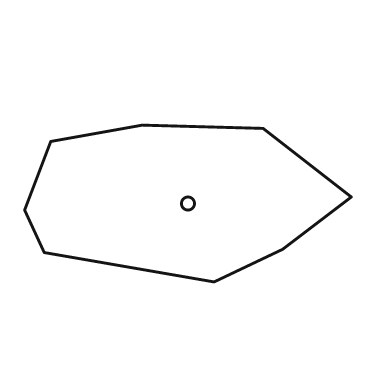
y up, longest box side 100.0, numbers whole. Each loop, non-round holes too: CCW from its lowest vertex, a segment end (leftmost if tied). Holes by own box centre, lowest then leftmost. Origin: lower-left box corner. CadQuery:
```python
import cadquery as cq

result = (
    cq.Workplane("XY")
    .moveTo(58.0, 0.0)
    .lineTo(79.0, 10.0)
    .lineTo(100.0, 26.0)
    .lineTo(73.0, 47.0)
    .lineTo(36.0, 48.0)
    .lineTo(8.0, 43.0)
    .lineTo(0.0, 22.0)
    .lineTo(6.0, 9.0)
    .close()
    .moveTo(50.0, 24.0)
    .circle(2.0)
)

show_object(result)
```